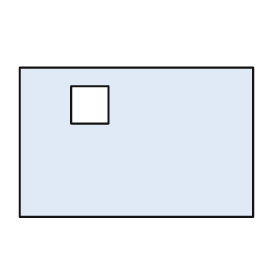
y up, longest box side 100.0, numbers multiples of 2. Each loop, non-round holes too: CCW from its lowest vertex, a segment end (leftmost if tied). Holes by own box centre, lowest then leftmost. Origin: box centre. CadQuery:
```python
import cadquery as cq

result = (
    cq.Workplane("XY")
    .moveTo(-50.0, -32.0)
    .lineTo(50.0, -32.0)
    .lineTo(50.0, 32.0)
    .lineTo(-50.0, 32.0)
    .close()
    .moveTo(-28.0, 8.0)
    .lineTo(-12.0, 8.0)
    .lineTo(-12.0, 24.0)
    .lineTo(-28.0, 24.0)
    .close()
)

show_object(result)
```